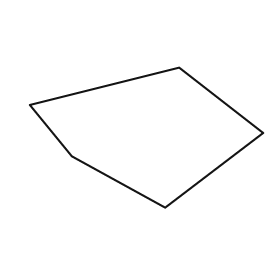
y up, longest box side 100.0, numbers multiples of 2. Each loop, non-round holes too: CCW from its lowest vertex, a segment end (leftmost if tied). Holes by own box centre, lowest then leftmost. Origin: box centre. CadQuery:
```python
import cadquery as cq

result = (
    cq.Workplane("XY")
    .moveTo(8.0, -30.0)
    .lineTo(50.0, 2.0)
    .lineTo(14.0, 30.0)
    .lineTo(-50.0, 14.0)
    .lineTo(-32.0, -8.0)
    .close()
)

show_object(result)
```